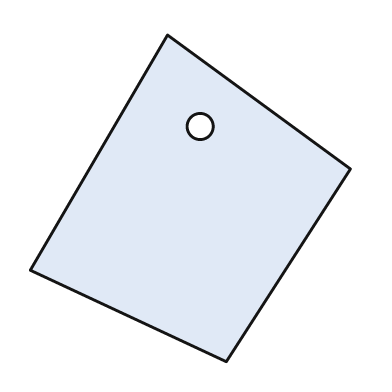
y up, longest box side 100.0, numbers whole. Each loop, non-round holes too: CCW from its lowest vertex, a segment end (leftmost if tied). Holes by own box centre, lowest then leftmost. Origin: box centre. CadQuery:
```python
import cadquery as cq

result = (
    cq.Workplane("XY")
    .moveTo(11.0, -50.0)
    .lineTo(49.0, 9.0)
    .lineTo(-7.0, 50.0)
    .lineTo(-49.0, -22.0)
    .close()
    .moveTo(3.0, 22.0)
    .circle(4.0)
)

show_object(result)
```